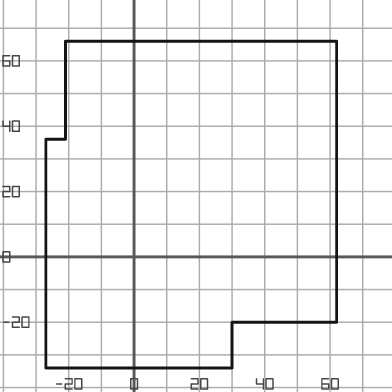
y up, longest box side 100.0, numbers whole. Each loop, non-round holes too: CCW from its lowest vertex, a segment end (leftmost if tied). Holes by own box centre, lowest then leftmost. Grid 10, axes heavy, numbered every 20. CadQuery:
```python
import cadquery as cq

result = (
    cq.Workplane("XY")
    .moveTo(-27.0, -34.0)
    .lineTo(30.0, -34.0)
    .lineTo(30.0, -20.0)
    .lineTo(62.0, -20.0)
    .lineTo(62.0, 66.0)
    .lineTo(-21.0, 66.0)
    .lineTo(-21.0, 36.0)
    .lineTo(-27.0, 36.0)
    .close()
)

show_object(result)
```